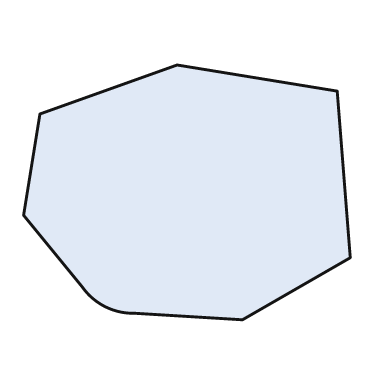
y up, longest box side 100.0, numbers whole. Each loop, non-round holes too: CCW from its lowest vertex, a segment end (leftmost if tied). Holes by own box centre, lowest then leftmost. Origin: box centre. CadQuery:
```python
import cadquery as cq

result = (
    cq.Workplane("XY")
    .moveTo(17.0, -39.0)
    .lineTo(50.0, -20.0)
    .lineTo(46.0, 31.0)
    .lineTo(-3.0, 39.0)
    .lineTo(-45.0, 24.0)
    .lineTo(-50.0, -7.0)
    .lineTo(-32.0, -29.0)
    .threePointArc((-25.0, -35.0), (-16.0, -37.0))
    .close()
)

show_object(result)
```